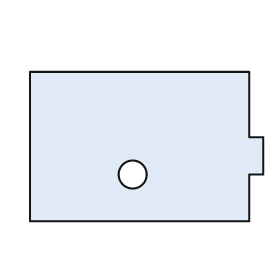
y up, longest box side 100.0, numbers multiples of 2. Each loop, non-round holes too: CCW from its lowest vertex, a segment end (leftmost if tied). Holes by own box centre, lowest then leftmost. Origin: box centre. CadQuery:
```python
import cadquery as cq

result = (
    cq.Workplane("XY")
    .moveTo(-50.0, -32.0)
    .lineTo(44.0, -32.0)
    .lineTo(44.0, -12.0)
    .lineTo(50.0, -12.0)
    .lineTo(50.0, 4.0)
    .lineTo(44.0, 4.0)
    .lineTo(44.0, 32.0)
    .lineTo(-50.0, 32.0)
    .close()
    .moveTo(-6.0, -12.0)
    .circle(6.0)
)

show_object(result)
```